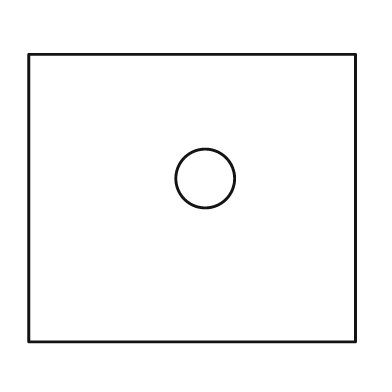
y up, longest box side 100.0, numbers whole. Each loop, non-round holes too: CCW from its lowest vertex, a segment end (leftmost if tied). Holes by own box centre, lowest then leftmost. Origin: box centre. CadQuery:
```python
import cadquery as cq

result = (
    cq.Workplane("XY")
    .moveTo(-50.0, -44.0)
    .lineTo(50.0, -44.0)
    .lineTo(50.0, 44.0)
    .lineTo(-50.0, 44.0)
    .close()
    .moveTo(4.0, 6.0)
    .circle(9.0)
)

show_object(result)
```